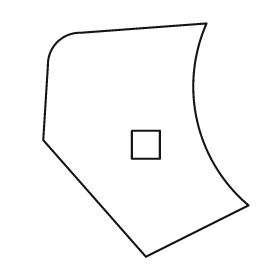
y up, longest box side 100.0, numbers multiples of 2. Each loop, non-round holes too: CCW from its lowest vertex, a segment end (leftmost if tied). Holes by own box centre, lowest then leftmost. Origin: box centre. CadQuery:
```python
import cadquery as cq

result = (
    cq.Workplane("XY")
    .moveTo(0.0, -50.0)
    .lineTo(44.0, -28.0)
    .threePointArc((22.0, 8.0), (26.0, 50.0))
    .lineTo(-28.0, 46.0)
    .threePointArc((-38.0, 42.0), (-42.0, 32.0))
    .lineTo(-44.0, 0.0)
    .close()
    .moveTo(-6.0, -8.0)
    .lineTo(6.0, -8.0)
    .lineTo(6.0, 4.0)
    .lineTo(-6.0, 4.0)
    .close()
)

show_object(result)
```